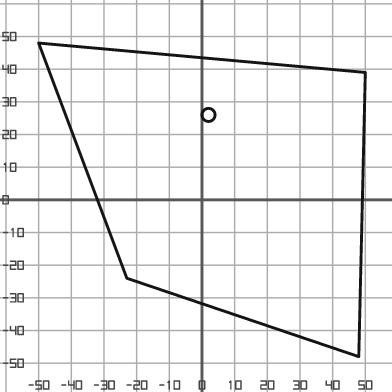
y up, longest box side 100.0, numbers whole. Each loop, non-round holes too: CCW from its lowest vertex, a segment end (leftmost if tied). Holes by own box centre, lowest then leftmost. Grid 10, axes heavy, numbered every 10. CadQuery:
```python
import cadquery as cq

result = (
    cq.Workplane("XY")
    .moveTo(48.0, -48.0)
    .lineTo(50.0, 39.0)
    .lineTo(-50.0, 48.0)
    .lineTo(-23.0, -24.0)
    .close()
    .moveTo(2.0, 26.0)
    .circle(2.0)
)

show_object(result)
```